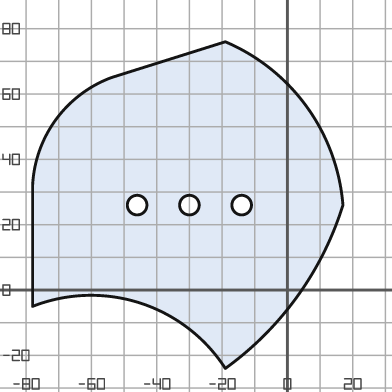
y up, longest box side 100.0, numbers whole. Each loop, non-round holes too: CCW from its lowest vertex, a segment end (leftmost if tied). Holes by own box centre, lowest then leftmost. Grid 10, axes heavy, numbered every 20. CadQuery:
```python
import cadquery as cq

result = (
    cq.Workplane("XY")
    .moveTo(-19.0, -24.0)
    .threePointArc((3.0, -2.0), (17.0, 26.0))
    .threePointArc((6.0, 56.0), (-19.0, 76.0))
    .lineTo(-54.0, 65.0)
    .threePointArc((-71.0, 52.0), (-78.0, 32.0))
    .lineTo(-78.0, -5.0)
    .threePointArc((-45.0, -4.0), (-19.0, -24.0))
    .close()
    .moveTo(-46.0, 26.0)
    .circle(3.0)
    .moveTo(-30.0, 26.0)
    .circle(3.0)
    .moveTo(-14.0, 26.0)
    .circle(3.0)
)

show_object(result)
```